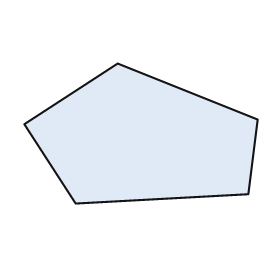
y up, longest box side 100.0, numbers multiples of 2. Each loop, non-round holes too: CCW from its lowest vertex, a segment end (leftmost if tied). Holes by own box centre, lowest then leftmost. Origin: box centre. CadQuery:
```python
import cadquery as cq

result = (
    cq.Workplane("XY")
    .moveTo(-28.0, -30.0)
    .lineTo(46.0, -26.0)
    .lineTo(50.0, 6.0)
    .lineTo(-10.0, 30.0)
    .lineTo(-50.0, 4.0)
    .close()
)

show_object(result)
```